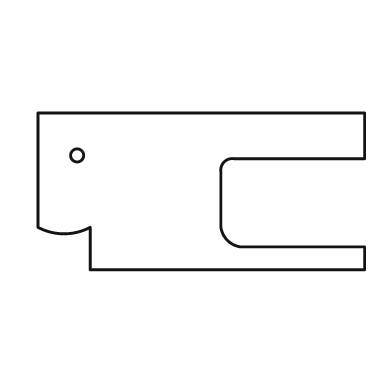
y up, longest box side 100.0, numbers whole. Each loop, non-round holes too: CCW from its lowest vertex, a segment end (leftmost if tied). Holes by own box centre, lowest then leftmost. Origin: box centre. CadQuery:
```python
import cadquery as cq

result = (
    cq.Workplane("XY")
    .moveTo(-34.0, -24.0)
    .lineTo(50.0, -24.0)
    .lineTo(50.0, -17.0)
    .lineTo(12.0, -17.0)
    .threePointArc((8.0, -15.0), (6.0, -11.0))
    .lineTo(6.0, 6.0)
    .threePointArc((7.0, 9.0), (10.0, 10.0))
    .lineTo(50.0, 10.0)
    .lineTo(50.0, 24.0)
    .lineTo(-50.0, 24.0)
    .lineTo(-50.0, -11.0)
    .threePointArc((-42.0, -13.0), (-34.0, -11.0))
    .close()
    .moveTo(-38.0, 11.0)
    .circle(2.0)
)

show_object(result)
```